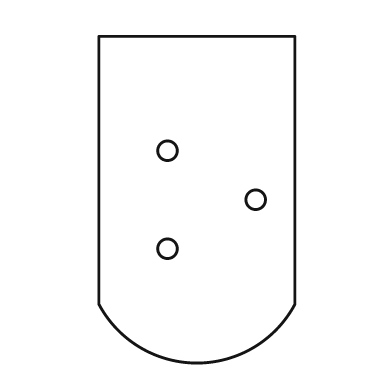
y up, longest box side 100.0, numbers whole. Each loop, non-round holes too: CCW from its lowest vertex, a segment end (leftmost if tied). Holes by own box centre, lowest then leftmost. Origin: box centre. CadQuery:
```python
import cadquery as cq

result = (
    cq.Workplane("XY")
    .moveTo(-30.0, -32.0)
    .threePointArc((0.0, -50.0), (30.0, -32.0))
    .lineTo(30.0, 50.0)
    .lineTo(-30.0, 50.0)
    .close()
    .moveTo(-9.0, -15.0)
    .circle(3.0)
    .moveTo(18.0, 0.0)
    .circle(3.0)
    .moveTo(-9.0, 15.0)
    .circle(3.0)
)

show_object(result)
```